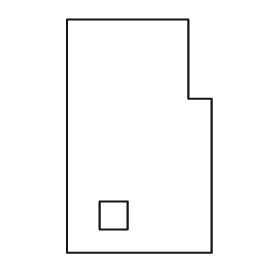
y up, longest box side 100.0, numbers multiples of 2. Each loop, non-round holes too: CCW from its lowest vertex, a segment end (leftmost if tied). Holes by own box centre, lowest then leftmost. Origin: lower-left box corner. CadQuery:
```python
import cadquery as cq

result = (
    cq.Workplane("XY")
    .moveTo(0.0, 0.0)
    .lineTo(62.0, 0.0)
    .lineTo(62.0, 66.0)
    .lineTo(52.0, 66.0)
    .lineTo(52.0, 100.0)
    .lineTo(0.0, 100.0)
    .close()
    .moveTo(14.0, 10.0)
    .lineTo(26.0, 10.0)
    .lineTo(26.0, 22.0)
    .lineTo(14.0, 22.0)
    .close()
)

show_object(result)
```